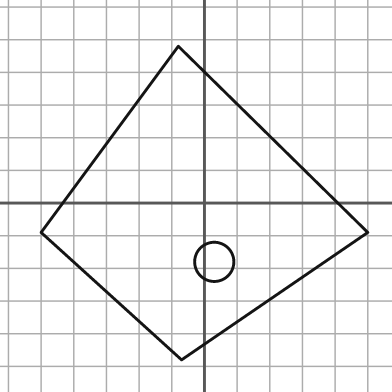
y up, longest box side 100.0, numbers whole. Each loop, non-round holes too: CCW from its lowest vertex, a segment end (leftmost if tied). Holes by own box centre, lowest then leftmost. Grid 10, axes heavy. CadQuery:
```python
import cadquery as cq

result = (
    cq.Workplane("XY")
    .moveTo(-7.0, -48.0)
    .lineTo(50.0, -9.0)
    .lineTo(-8.0, 48.0)
    .lineTo(-50.0, -9.0)
    .close()
    .moveTo(3.0, -18.0)
    .circle(6.0)
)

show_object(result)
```